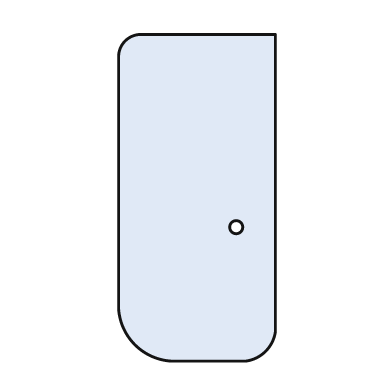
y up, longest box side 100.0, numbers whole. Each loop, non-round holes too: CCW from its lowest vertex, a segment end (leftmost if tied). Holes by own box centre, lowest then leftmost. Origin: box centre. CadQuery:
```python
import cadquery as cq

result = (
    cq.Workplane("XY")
    .moveTo(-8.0, -50.0)
    .lineTo(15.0, -50.0)
    .threePointArc((21.0, -47.0), (24.0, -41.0))
    .lineTo(24.0, 50.0)
    .lineTo(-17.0, 50.0)
    .threePointArc((-22.0, 48.0), (-24.0, 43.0))
    .lineTo(-24.0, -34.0)
    .threePointArc((-19.0, -45.0), (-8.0, -50.0))
    .close()
    .moveTo(12.0, -9.0)
    .circle(2.0)
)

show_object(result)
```